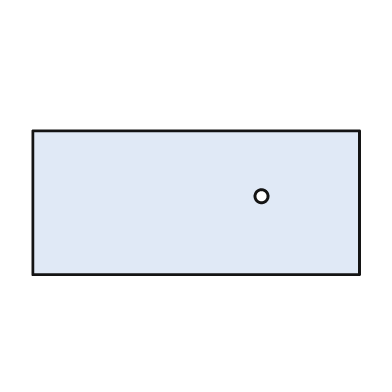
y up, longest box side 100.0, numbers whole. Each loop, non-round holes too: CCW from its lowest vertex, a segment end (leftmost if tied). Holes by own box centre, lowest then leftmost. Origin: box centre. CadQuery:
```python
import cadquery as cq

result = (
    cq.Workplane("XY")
    .moveTo(-50.0, -22.0)
    .lineTo(50.0, -22.0)
    .lineTo(50.0, 22.0)
    .lineTo(-50.0, 22.0)
    .close()
    .moveTo(20.0, 2.0)
    .circle(2.0)
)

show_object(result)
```